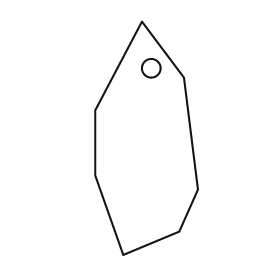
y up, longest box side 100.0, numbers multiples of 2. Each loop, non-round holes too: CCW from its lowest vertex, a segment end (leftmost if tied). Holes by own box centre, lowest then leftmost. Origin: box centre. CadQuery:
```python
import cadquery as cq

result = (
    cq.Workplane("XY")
    .moveTo(-10.0, -50.0)
    .lineTo(14.0, -40.0)
    .lineTo(22.0, -22.0)
    .lineTo(16.0, 26.0)
    .lineTo(-2.0, 50.0)
    .lineTo(-22.0, 12.0)
    .lineTo(-22.0, -16.0)
    .close()
    .moveTo(2.0, 30.0)
    .circle(4.0)
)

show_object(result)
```